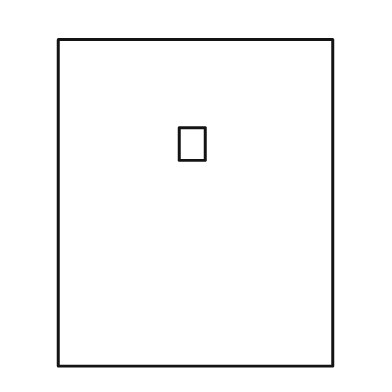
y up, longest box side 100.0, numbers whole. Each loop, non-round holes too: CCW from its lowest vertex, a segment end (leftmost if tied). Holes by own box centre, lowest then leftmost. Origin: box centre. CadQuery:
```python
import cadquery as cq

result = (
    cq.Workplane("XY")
    .moveTo(-42.0, -50.0)
    .lineTo(42.0, -50.0)
    .lineTo(42.0, 50.0)
    .lineTo(-42.0, 50.0)
    .close()
    .moveTo(-5.0, 13.0)
    .lineTo(3.0, 13.0)
    .lineTo(3.0, 23.0)
    .lineTo(-5.0, 23.0)
    .close()
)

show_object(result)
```